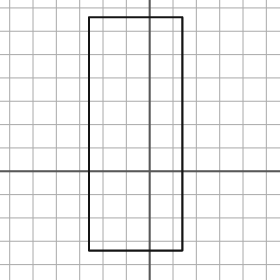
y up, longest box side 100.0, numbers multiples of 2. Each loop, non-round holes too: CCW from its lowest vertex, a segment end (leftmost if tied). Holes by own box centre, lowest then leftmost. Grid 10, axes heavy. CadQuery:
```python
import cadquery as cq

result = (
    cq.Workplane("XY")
    .moveTo(-26.0, -34.0)
    .lineTo(14.0, -34.0)
    .lineTo(14.0, 66.0)
    .lineTo(-26.0, 66.0)
    .close()
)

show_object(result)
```